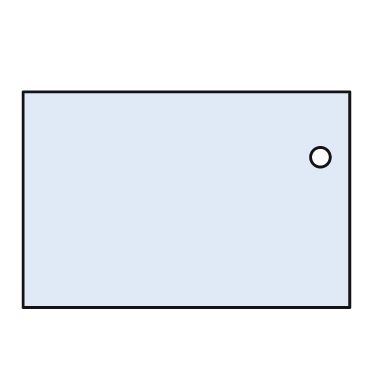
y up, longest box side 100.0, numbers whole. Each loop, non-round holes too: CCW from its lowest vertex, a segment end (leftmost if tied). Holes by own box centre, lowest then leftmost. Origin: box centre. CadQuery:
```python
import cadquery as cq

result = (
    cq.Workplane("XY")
    .moveTo(-50.0, -33.0)
    .lineTo(50.0, -33.0)
    .lineTo(50.0, 33.0)
    .lineTo(-50.0, 33.0)
    .close()
    .moveTo(41.0, 13.0)
    .circle(3.0)
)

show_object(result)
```